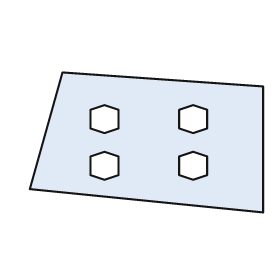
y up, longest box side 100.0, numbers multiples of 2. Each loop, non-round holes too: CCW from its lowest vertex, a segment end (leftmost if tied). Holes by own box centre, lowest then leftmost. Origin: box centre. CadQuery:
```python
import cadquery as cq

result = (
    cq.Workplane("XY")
    .moveTo(50.0, -30.0)
    .lineTo(50.0, 24.0)
    .lineTo(-36.0, 30.0)
    .lineTo(-50.0, -20.0)
    .close()
    .moveTo(-18.0, -16.0)
    .lineTo(-12.0, -14.0)
    .lineTo(-12.0, -6.0)
    .lineTo(-18.0, -4.0)
    .lineTo(-24.0, -6.0)
    .lineTo(-24.0, -14.0)
    .close()
    .moveTo(20.0, -16.0)
    .lineTo(26.0, -14.0)
    .lineTo(26.0, -6.0)
    .lineTo(20.0, -4.0)
    .lineTo(14.0, -6.0)
    .lineTo(14.0, -14.0)
    .close()
    .moveTo(-18.0, 4.0)
    .lineTo(-12.0, 6.0)
    .lineTo(-12.0, 14.0)
    .lineTo(-18.0, 16.0)
    .lineTo(-24.0, 14.0)
    .lineTo(-24.0, 6.0)
    .close()
    .moveTo(20.0, 4.0)
    .lineTo(26.0, 6.0)
    .lineTo(26.0, 14.0)
    .lineTo(20.0, 16.0)
    .lineTo(14.0, 14.0)
    .lineTo(14.0, 6.0)
    .close()
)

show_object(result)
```